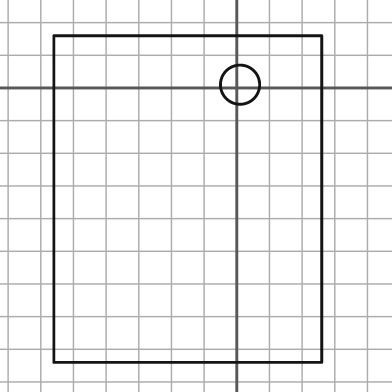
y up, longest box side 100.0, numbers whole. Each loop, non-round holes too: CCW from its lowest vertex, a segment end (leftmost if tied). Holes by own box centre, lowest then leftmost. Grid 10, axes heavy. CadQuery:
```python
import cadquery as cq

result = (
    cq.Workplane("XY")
    .moveTo(-56.0, -84.0)
    .lineTo(26.0, -84.0)
    .lineTo(26.0, 16.0)
    .lineTo(-56.0, 16.0)
    .close()
    .moveTo(1.0, 1.0)
    .circle(6.0)
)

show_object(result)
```